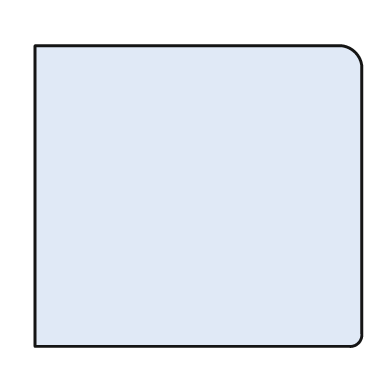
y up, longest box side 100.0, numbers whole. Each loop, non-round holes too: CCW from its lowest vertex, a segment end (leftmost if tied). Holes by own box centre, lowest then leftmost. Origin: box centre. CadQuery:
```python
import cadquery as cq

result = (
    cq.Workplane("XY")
    .moveTo(-50.0, -46.0)
    .lineTo(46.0, -46.0)
    .threePointArc((49.0, -45.0), (50.0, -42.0))
    .lineTo(50.0, 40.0)
    .threePointArc((48.0, 44.0), (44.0, 46.0))
    .lineTo(-50.0, 46.0)
    .close()
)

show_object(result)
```